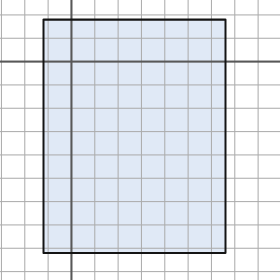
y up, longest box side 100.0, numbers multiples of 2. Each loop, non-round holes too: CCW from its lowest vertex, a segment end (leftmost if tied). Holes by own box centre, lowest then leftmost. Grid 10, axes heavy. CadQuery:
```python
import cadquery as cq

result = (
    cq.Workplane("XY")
    .moveTo(-12.0, -82.0)
    .lineTo(66.0, -82.0)
    .lineTo(66.0, 18.0)
    .lineTo(-12.0, 18.0)
    .close()
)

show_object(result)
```